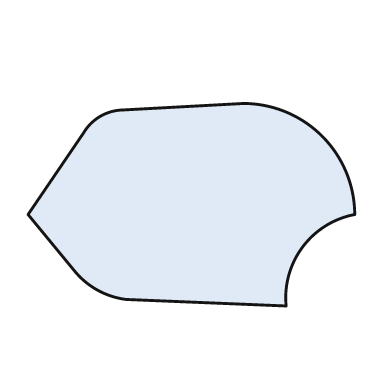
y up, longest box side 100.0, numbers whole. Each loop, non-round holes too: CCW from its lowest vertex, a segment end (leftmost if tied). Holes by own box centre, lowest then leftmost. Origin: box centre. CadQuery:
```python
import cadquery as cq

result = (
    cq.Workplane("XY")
    .moveTo(29.0, -31.0)
    .threePointArc((34.0, -13.0), (50.0, -3.0))
    .threePointArc((40.0, 21.0), (16.0, 31.0))
    .lineTo(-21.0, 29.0)
    .threePointArc((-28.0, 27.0), (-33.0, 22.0))
    .lineTo(-50.0, -3.0)
    .lineTo(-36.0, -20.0)
    .threePointArc((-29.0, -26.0), (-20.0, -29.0))
    .close()
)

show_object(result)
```